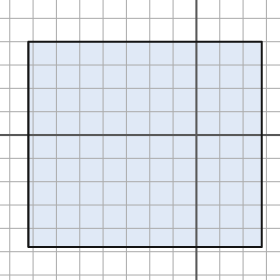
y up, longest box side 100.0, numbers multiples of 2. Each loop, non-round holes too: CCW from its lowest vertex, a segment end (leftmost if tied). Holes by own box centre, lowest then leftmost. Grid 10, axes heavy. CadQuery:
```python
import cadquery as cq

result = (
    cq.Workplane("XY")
    .moveTo(-72.0, -48.0)
    .lineTo(28.0, -48.0)
    .lineTo(28.0, 40.0)
    .lineTo(-72.0, 40.0)
    .close()
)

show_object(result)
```